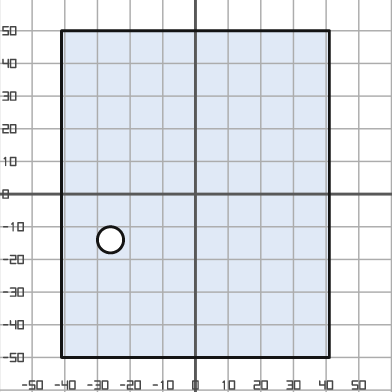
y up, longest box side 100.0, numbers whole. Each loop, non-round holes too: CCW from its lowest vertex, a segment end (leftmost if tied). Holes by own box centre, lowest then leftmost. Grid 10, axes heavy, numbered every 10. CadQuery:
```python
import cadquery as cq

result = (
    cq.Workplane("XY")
    .moveTo(-41.0, -50.0)
    .lineTo(41.0, -50.0)
    .lineTo(41.0, 50.0)
    .lineTo(-41.0, 50.0)
    .close()
    .moveTo(-26.0, -14.0)
    .circle(4.0)
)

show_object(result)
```